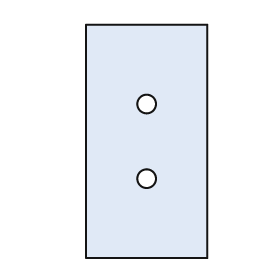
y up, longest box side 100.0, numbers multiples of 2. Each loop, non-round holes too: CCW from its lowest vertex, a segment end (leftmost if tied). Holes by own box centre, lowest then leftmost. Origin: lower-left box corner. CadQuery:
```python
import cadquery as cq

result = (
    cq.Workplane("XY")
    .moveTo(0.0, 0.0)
    .lineTo(52.0, 0.0)
    .lineTo(52.0, 100.0)
    .lineTo(0.0, 100.0)
    .close()
    .moveTo(26.0, 34.0)
    .circle(4.0)
    .moveTo(26.0, 66.0)
    .circle(4.0)
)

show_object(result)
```